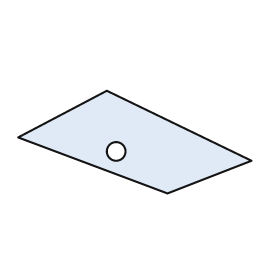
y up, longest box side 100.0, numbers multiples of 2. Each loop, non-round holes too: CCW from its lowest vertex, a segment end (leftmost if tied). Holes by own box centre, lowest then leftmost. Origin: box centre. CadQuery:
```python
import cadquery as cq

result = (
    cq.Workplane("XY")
    .moveTo(14.0, -22.0)
    .lineTo(50.0, -8.0)
    .lineTo(-12.0, 22.0)
    .lineTo(-50.0, 2.0)
    .close()
    .moveTo(-8.0, -4.0)
    .circle(4.0)
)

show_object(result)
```